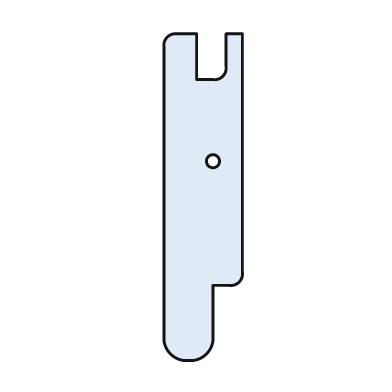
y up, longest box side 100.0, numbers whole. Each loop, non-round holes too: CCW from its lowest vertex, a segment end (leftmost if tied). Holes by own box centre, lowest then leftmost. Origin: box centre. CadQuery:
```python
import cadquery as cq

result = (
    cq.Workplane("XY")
    .moveTo(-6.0, -50.0)
    .lineTo(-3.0, -50.0)
    .threePointArc((1.0, -48.0), (3.0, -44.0))
    .lineTo(3.0, -27.0)
    .lineTo(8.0, -27.0)
    .threePointArc((11.0, -26.0), (12.0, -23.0))
    .lineTo(12.0, 50.0)
    .lineTo(7.0, 50.0)
    .lineTo(7.0, 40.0)
    .threePointArc((6.0, 37.0), (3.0, 36.0))
    .lineTo(-2.0, 36.0)
    .lineTo(-2.0, 50.0)
    .lineTo(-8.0, 50.0)
    .threePointArc((-11.0, 49.0), (-12.0, 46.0))
    .lineTo(-12.0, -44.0)
    .threePointArc((-10.0, -48.0), (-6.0, -50.0))
    .close()
    .moveTo(3.0, 11.0)
    .circle(2.0)
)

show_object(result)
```